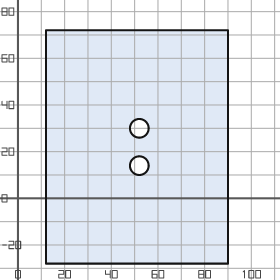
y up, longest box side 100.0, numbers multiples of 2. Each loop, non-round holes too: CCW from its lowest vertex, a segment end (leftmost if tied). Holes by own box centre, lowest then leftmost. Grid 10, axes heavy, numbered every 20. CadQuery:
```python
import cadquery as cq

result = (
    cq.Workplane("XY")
    .moveTo(12.0, -28.0)
    .lineTo(90.0, -28.0)
    .lineTo(90.0, 72.0)
    .lineTo(12.0, 72.0)
    .close()
    .moveTo(52.0, 14.0)
    .circle(4.0)
    .moveTo(52.0, 30.0)
    .circle(4.0)
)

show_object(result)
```